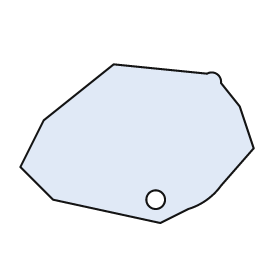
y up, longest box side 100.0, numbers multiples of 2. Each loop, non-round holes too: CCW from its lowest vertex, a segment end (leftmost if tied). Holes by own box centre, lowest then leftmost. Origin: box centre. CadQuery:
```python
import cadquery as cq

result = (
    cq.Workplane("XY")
    .moveTo(10.0, -34.0)
    .lineTo(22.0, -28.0)
    .threePointArc((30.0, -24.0), (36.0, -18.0))
    .lineTo(50.0, -2.0)
    .lineTo(44.0, 16.0)
    .lineTo(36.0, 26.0)
    .threePointArc((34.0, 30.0), (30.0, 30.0))
    .lineTo(-10.0, 34.0)
    .lineTo(-40.0, 10.0)
    .lineTo(-50.0, -10.0)
    .lineTo(-36.0, -24.0)
    .close()
    .moveTo(8.0, -24.0)
    .circle(4.0)
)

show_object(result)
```